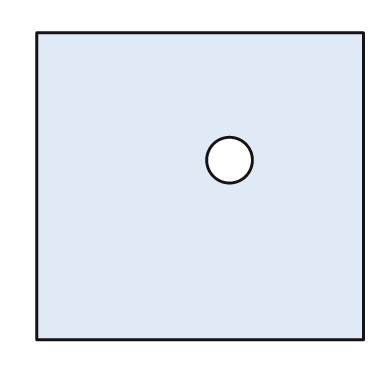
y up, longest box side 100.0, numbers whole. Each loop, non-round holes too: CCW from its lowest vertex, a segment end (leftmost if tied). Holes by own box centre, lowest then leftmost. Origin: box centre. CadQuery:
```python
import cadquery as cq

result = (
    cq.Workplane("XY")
    .moveTo(-50.0, -47.0)
    .lineTo(50.0, -47.0)
    .lineTo(50.0, 47.0)
    .lineTo(-50.0, 47.0)
    .close()
    .moveTo(9.0, 8.0)
    .circle(7.0)
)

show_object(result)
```